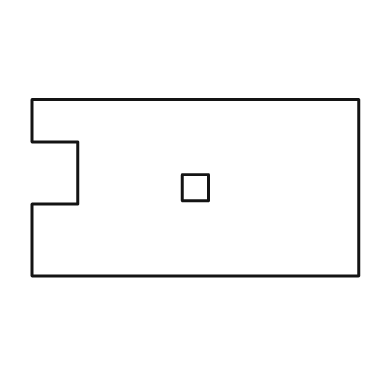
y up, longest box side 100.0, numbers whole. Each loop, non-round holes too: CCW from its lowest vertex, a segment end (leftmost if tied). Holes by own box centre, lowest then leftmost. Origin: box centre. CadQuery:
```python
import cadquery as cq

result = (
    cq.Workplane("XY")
    .moveTo(-50.0, -27.0)
    .lineTo(50.0, -27.0)
    .lineTo(50.0, 27.0)
    .lineTo(-50.0, 27.0)
    .lineTo(-50.0, 14.0)
    .lineTo(-36.0, 14.0)
    .lineTo(-36.0, -5.0)
    .lineTo(-50.0, -5.0)
    .close()
    .moveTo(-4.0, -4.0)
    .lineTo(4.0, -4.0)
    .lineTo(4.0, 4.0)
    .lineTo(-4.0, 4.0)
    .close()
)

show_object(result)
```